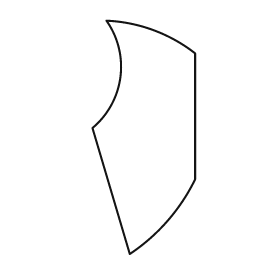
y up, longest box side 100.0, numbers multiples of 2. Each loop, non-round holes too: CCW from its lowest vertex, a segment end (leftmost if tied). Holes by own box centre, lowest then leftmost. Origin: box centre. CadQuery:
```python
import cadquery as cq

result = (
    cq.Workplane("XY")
    .moveTo(-6.0, -50.0)
    .threePointArc((10.0, -36.0), (22.0, -18.0))
    .lineTo(22.0, 36.0)
    .threePointArc((4.0, 46.0), (-16.0, 50.0))
    .threePointArc((-10.0, 26.0), (-22.0, 4.0))
    .close()
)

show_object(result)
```